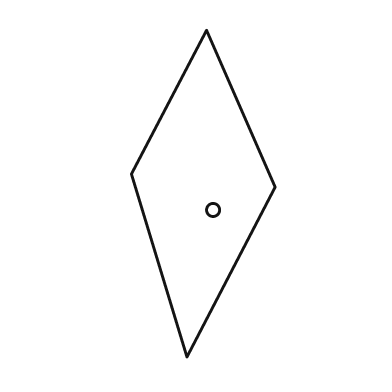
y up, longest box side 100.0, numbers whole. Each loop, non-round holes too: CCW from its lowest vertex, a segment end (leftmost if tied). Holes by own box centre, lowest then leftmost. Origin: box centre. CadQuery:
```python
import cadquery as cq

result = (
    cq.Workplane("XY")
    .moveTo(-5.0, -50.0)
    .lineTo(22.0, 2.0)
    .lineTo(1.0, 50.0)
    .lineTo(-22.0, 6.0)
    .close()
    .moveTo(3.0, -5.0)
    .circle(2.0)
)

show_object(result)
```